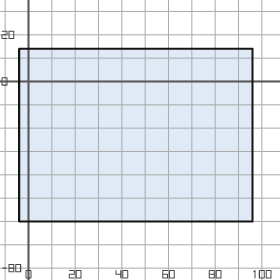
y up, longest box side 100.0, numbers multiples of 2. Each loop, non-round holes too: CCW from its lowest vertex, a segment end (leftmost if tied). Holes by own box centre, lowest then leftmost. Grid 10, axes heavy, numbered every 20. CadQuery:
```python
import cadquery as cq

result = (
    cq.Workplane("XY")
    .moveTo(-4.0, -60.0)
    .lineTo(96.0, -60.0)
    .lineTo(96.0, 14.0)
    .lineTo(-4.0, 14.0)
    .close()
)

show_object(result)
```